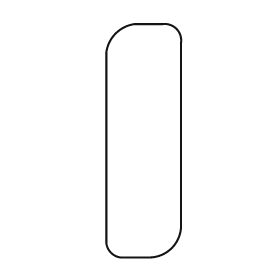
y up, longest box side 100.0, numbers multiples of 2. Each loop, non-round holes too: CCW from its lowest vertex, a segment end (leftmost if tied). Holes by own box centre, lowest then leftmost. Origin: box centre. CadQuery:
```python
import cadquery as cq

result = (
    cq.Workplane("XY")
    .moveTo(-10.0, -50.0)
    .lineTo(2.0, -50.0)
    .threePointArc((12.0, -46.0), (16.0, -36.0))
    .lineTo(16.0, 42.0)
    .threePointArc((14.0, 48.0), (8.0, 50.0))
    .lineTo(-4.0, 50.0)
    .threePointArc((-12.0, 46.0), (-16.0, 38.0))
    .lineTo(-16.0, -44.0)
    .threePointArc((-14.0, -48.0), (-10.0, -50.0))
    .close()
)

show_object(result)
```